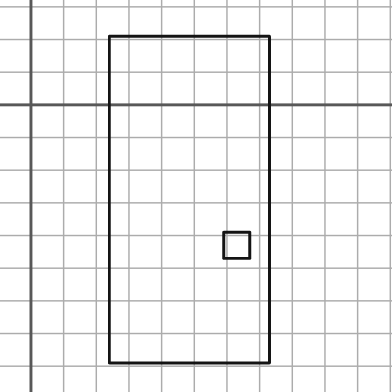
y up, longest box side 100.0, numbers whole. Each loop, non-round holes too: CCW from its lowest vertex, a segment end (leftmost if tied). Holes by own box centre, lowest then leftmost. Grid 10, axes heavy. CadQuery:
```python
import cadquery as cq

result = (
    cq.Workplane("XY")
    .moveTo(24.0, -79.0)
    .lineTo(73.0, -79.0)
    .lineTo(73.0, 21.0)
    .lineTo(24.0, 21.0)
    .close()
    .moveTo(59.0, -47.0)
    .lineTo(67.0, -47.0)
    .lineTo(67.0, -39.0)
    .lineTo(59.0, -39.0)
    .close()
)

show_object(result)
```